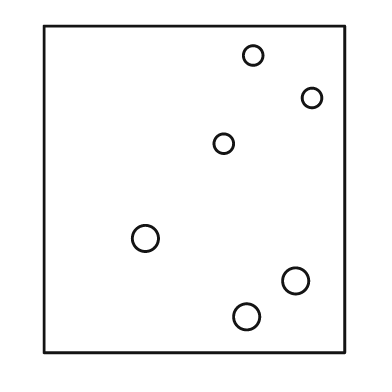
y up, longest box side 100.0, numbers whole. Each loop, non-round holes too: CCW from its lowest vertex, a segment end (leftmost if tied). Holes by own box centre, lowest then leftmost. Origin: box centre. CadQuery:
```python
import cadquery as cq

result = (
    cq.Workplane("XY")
    .moveTo(-46.0, -50.0)
    .lineTo(46.0, -50.0)
    .lineTo(46.0, 50.0)
    .lineTo(-46.0, 50.0)
    .close()
    .moveTo(16.0, -39.0)
    .circle(4.0)
    .moveTo(31.0, -28.0)
    .circle(4.0)
    .moveTo(-15.0, -15.0)
    .circle(4.0)
    .moveTo(9.0, 14.0)
    .circle(3.0)
    .moveTo(36.0, 28.0)
    .circle(3.0)
    .moveTo(18.0, 41.0)
    .circle(3.0)
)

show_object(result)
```